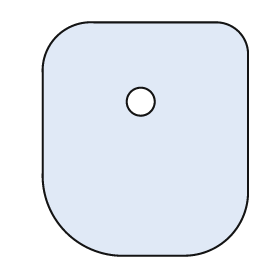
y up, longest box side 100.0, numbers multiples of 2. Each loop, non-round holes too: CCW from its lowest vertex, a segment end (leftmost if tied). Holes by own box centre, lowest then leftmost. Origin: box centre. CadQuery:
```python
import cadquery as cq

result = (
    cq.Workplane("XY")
    .moveTo(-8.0, -50.0)
    .lineTo(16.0, -50.0)
    .threePointArc((36.0, -42.0), (44.0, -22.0))
    .lineTo(44.0, 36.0)
    .threePointArc((40.0, 46.0), (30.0, 50.0))
    .lineTo(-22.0, 50.0)
    .threePointArc((-38.0, 44.0), (-44.0, 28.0))
    .lineTo(-44.0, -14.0)
    .threePointArc((-34.0, -40.0), (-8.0, -50.0))
    .close()
    .moveTo(-2.0, 16.0)
    .circle(6.0)
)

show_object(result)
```